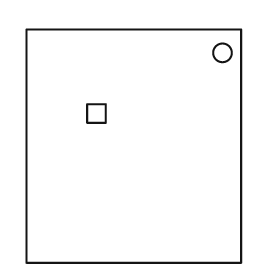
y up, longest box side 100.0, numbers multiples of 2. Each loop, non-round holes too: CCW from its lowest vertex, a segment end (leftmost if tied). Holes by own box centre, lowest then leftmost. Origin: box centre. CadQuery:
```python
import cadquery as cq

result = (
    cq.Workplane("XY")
    .moveTo(-46.0, -50.0)
    .lineTo(46.0, -50.0)
    .lineTo(46.0, 50.0)
    .lineTo(-46.0, 50.0)
    .close()
    .moveTo(-20.0, 10.0)
    .lineTo(-12.0, 10.0)
    .lineTo(-12.0, 18.0)
    .lineTo(-20.0, 18.0)
    .close()
    .moveTo(38.0, 40.0)
    .circle(4.0)
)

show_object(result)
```